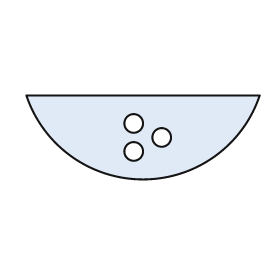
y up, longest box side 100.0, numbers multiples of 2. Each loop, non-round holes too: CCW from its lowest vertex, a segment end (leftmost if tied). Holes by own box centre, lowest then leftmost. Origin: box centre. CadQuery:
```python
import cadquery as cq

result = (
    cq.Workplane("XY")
    .moveTo(-50.0, 18.0)
    .threePointArc((0.0, -18.0), (50.0, 18.0))
    .close()
    .moveTo(-4.0, -6.0)
    .circle(4.0)
    .moveTo(8.0, 0.0)
    .circle(4.0)
    .moveTo(-4.0, 6.0)
    .circle(4.0)
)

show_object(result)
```